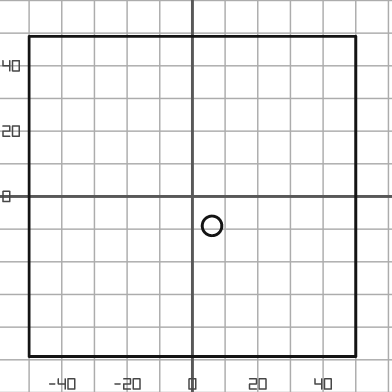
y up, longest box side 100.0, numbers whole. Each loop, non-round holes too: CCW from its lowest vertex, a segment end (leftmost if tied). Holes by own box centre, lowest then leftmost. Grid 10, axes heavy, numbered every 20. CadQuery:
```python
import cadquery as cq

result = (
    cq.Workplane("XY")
    .moveTo(-50.0, -49.0)
    .lineTo(50.0, -49.0)
    .lineTo(50.0, 49.0)
    .lineTo(-50.0, 49.0)
    .close()
    .moveTo(6.0, -9.0)
    .circle(3.0)
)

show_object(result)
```